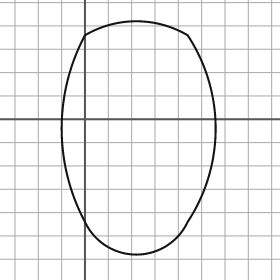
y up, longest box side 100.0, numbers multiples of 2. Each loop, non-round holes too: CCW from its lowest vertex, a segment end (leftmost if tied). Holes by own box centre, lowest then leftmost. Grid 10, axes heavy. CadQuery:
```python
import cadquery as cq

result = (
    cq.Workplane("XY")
    .moveTo(0.0, -44.0)
    .threePointArc((22.0, -58.0), (44.0, -44.0))
    .threePointArc((56.0, -4.0), (44.0, 36.0))
    .threePointArc((22.0, 42.0), (0.0, 36.0))
    .threePointArc((-10.0, -4.0), (0.0, -44.0))
    .close()
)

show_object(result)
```